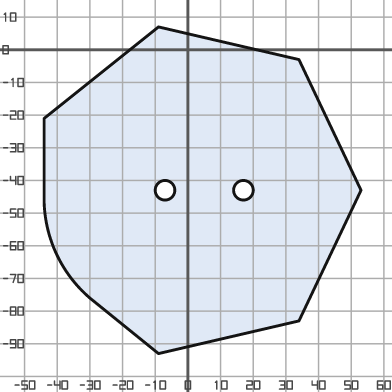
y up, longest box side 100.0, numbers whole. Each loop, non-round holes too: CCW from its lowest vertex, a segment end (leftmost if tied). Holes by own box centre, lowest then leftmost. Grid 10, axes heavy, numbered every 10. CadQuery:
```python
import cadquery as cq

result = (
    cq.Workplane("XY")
    .moveTo(-9.0, -93.0)
    .lineTo(34.0, -83.0)
    .lineTo(53.0, -43.0)
    .lineTo(34.0, -3.0)
    .lineTo(-9.0, 7.0)
    .lineTo(-44.0, -21.0)
    .lineTo(-44.0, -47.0)
    .threePointArc((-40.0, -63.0), (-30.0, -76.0))
    .close()
    .moveTo(-7.0, -43.0)
    .circle(3.0)
    .moveTo(17.0, -43.0)
    .circle(3.0)
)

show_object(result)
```